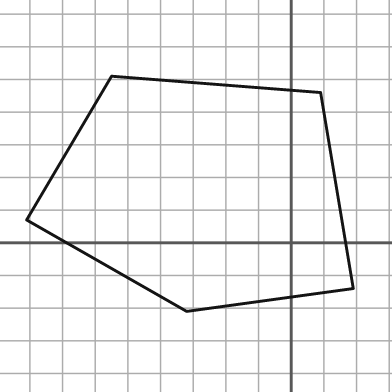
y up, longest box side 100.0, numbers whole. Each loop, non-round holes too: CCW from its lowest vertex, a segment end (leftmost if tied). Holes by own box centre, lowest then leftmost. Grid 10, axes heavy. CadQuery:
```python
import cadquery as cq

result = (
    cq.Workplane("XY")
    .moveTo(-32.0, -21.0)
    .lineTo(19.0, -14.0)
    .lineTo(9.0, 46.0)
    .lineTo(-55.0, 51.0)
    .lineTo(-81.0, 7.0)
    .close()
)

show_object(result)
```